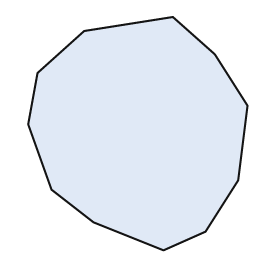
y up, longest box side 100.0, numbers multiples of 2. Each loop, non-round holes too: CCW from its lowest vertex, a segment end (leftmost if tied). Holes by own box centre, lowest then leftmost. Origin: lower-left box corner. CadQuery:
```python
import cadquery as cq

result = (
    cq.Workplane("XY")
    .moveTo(58.0, 0.0)
    .lineTo(76.0, 8.0)
    .lineTo(90.0, 30.0)
    .lineTo(94.0, 62.0)
    .lineTo(80.0, 84.0)
    .lineTo(62.0, 100.0)
    .lineTo(24.0, 94.0)
    .lineTo(4.0, 76.0)
    .lineTo(0.0, 54.0)
    .lineTo(10.0, 26.0)
    .lineTo(28.0, 12.0)
    .close()
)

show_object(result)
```